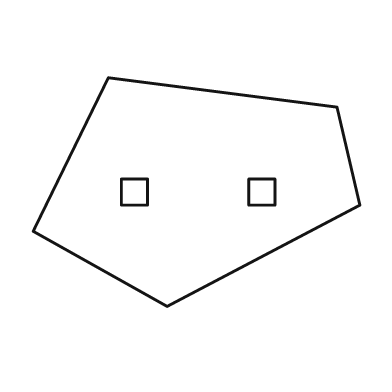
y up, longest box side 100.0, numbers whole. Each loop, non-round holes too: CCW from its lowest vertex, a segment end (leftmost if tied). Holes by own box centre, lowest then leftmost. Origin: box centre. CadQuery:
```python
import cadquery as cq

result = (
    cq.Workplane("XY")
    .moveTo(-9.0, -35.0)
    .lineTo(50.0, -4.0)
    .lineTo(43.0, 26.0)
    .lineTo(-27.0, 35.0)
    .lineTo(-50.0, -12.0)
    .close()
    .moveTo(-23.0, -4.0)
    .lineTo(-15.0, -4.0)
    .lineTo(-15.0, 4.0)
    .lineTo(-23.0, 4.0)
    .close()
    .moveTo(16.0, -4.0)
    .lineTo(24.0, -4.0)
    .lineTo(24.0, 4.0)
    .lineTo(16.0, 4.0)
    .close()
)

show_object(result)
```